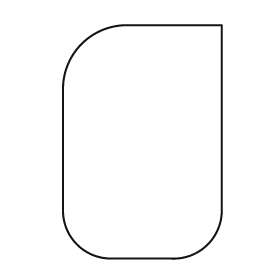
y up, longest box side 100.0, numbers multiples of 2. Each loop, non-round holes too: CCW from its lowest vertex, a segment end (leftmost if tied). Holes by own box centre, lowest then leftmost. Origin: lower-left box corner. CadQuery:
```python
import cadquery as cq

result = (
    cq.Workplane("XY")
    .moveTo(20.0, 0.0)
    .lineTo(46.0, 0.0)
    .threePointArc((62.0, 6.0), (68.0, 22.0))
    .lineTo(68.0, 100.0)
    .lineTo(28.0, 100.0)
    .threePointArc((8.0, 92.0), (0.0, 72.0))
    .lineTo(0.0, 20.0)
    .threePointArc((6.0, 6.0), (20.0, 0.0))
    .close()
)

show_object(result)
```